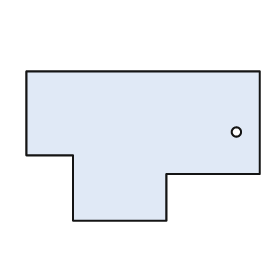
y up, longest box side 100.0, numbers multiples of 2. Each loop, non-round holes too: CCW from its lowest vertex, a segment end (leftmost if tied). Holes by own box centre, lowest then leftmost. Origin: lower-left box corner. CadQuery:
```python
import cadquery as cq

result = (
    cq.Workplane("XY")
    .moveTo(20.0, 0.0)
    .lineTo(60.0, 0.0)
    .lineTo(60.0, 20.0)
    .lineTo(100.0, 20.0)
    .lineTo(100.0, 64.0)
    .lineTo(0.0, 64.0)
    .lineTo(0.0, 28.0)
    .lineTo(20.0, 28.0)
    .close()
    .moveTo(90.0, 38.0)
    .circle(2.0)
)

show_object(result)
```